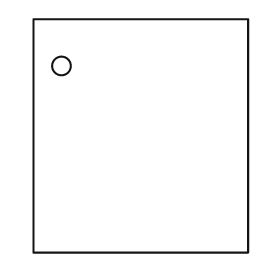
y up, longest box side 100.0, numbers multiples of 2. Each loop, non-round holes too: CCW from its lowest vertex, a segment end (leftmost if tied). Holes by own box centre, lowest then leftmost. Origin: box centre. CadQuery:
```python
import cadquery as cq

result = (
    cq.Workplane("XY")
    .moveTo(-46.0, -50.0)
    .lineTo(46.0, -50.0)
    .lineTo(46.0, 50.0)
    .lineTo(-46.0, 50.0)
    .close()
    .moveTo(-34.0, 30.0)
    .circle(4.0)
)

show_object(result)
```